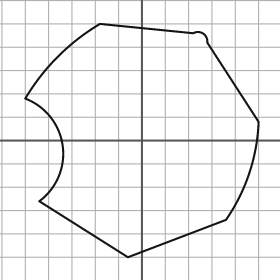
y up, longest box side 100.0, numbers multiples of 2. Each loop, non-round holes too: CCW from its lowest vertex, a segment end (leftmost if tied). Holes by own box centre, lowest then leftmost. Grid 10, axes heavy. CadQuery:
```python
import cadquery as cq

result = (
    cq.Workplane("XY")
    .moveTo(-6.0, -50.0)
    .lineTo(36.0, -34.0)
    .threePointArc((46.0, -14.0), (50.0, 8.0))
    .lineTo(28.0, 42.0)
    .threePointArc((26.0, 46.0), (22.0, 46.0))
    .lineTo(-18.0, 50.0)
    .threePointArc((-36.0, 36.0), (-50.0, 18.0))
    .threePointArc((-34.0, -2.0), (-44.0, -26.0))
    .close()
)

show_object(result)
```